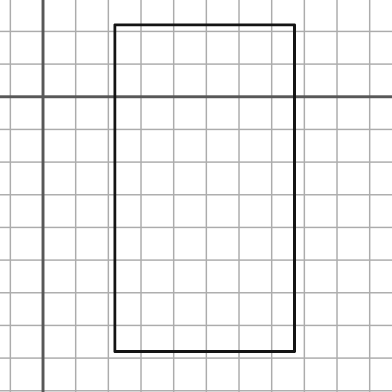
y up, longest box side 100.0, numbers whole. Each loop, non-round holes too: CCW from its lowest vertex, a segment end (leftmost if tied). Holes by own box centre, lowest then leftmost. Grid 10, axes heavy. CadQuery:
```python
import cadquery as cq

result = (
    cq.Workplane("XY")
    .moveTo(22.0, -78.0)
    .lineTo(77.0, -78.0)
    .lineTo(77.0, 22.0)
    .lineTo(22.0, 22.0)
    .close()
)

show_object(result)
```